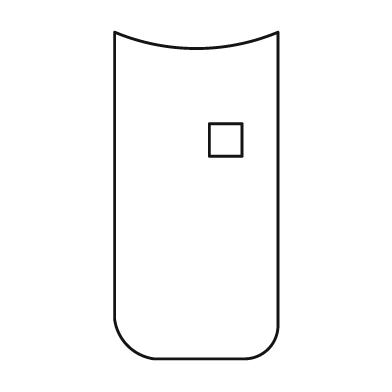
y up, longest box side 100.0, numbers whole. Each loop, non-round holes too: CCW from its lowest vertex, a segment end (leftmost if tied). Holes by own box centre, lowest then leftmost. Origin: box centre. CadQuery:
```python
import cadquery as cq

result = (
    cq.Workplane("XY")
    .moveTo(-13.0, -50.0)
    .lineTo(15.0, -50.0)
    .threePointArc((22.0, -47.0), (25.0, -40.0))
    .lineTo(25.0, 50.0)
    .threePointArc((0.0, 45.0), (-25.0, 50.0))
    .lineTo(-25.0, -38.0)
    .threePointArc((-21.0, -46.0), (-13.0, -50.0))
    .close()
    .moveTo(4.0, 12.0)
    .lineTo(14.0, 12.0)
    .lineTo(14.0, 22.0)
    .lineTo(4.0, 22.0)
    .close()
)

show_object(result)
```